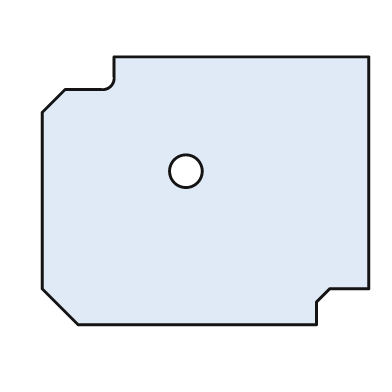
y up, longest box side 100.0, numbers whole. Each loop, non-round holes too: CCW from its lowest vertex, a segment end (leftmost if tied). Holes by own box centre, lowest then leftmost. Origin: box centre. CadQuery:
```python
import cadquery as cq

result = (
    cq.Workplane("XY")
    .moveTo(-39.0, -41.0)
    .lineTo(34.0, -41.0)
    .lineTo(34.0, -34.0)
    .lineTo(38.0, -30.0)
    .lineTo(50.0, -30.0)
    .lineTo(50.0, 41.0)
    .lineTo(-28.0, 41.0)
    .lineTo(-28.0, 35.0)
    .threePointArc((-29.0, 32.0), (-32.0, 31.0))
    .lineTo(-43.0, 31.0)
    .lineTo(-50.0, 24.0)
    .lineTo(-50.0, -30.0)
    .close()
    .moveTo(-6.0, 6.0)
    .circle(5.0)
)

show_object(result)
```